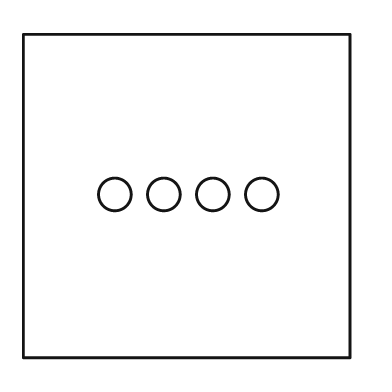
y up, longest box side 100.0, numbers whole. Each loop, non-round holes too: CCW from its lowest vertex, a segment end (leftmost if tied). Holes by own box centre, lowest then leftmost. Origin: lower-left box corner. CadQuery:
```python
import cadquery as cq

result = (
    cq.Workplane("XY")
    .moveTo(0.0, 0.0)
    .lineTo(100.0, 0.0)
    .lineTo(100.0, 99.0)
    .lineTo(0.0, 99.0)
    .close()
    .moveTo(28.0, 50.0)
    .circle(5.0)
    .moveTo(43.0, 50.0)
    .circle(5.0)
    .moveTo(58.0, 50.0)
    .circle(5.0)
    .moveTo(73.0, 50.0)
    .circle(5.0)
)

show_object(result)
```